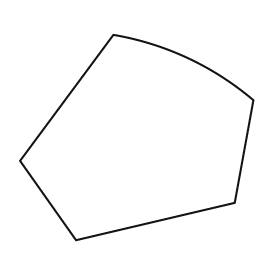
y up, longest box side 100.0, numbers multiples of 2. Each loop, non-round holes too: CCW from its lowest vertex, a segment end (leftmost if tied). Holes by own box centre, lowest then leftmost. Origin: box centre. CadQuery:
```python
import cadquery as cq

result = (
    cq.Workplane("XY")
    .moveTo(-26.0, -44.0)
    .lineTo(42.0, -28.0)
    .lineTo(50.0, 16.0)
    .threePointArc((22.0, 34.0), (-10.0, 44.0))
    .lineTo(-50.0, -10.0)
    .close()
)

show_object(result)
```